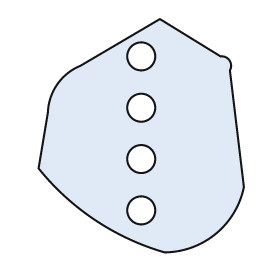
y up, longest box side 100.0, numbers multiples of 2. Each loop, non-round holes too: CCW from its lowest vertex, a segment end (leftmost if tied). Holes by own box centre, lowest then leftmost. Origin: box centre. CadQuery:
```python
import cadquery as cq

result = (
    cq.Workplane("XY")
    .moveTo(10.0, -50.0)
    .threePointArc((32.0, -42.0), (44.0, -22.0))
    .lineTo(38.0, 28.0)
    .threePointArc((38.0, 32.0), (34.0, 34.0))
    .lineTo(8.0, 50.0)
    .lineTo(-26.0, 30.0)
    .threePointArc((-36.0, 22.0), (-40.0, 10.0))
    .lineTo(-44.0, -14.0)
    .threePointArc((-20.0, -36.0), (10.0, -50.0))
    .close()
    .moveTo(0.0, -32.0)
    .circle(6.0)
    .moveTo(0.0, -10.0)
    .circle(6.0)
    .moveTo(0.0, 12.0)
    .circle(6.0)
    .moveTo(0.0, 34.0)
    .circle(6.0)
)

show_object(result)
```